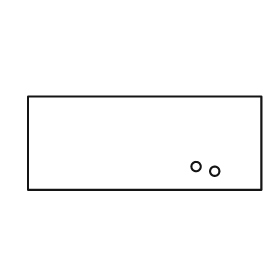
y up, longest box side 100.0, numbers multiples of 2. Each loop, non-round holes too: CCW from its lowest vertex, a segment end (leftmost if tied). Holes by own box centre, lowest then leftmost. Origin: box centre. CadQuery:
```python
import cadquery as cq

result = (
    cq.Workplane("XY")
    .moveTo(-50.0, -20.0)
    .lineTo(50.0, -20.0)
    .lineTo(50.0, 20.0)
    .lineTo(-50.0, 20.0)
    .close()
    .moveTo(30.0, -12.0)
    .circle(2.0)
    .moveTo(22.0, -10.0)
    .circle(2.0)
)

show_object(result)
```